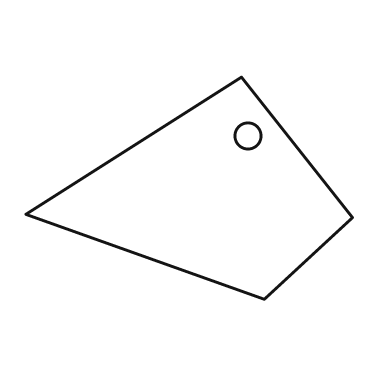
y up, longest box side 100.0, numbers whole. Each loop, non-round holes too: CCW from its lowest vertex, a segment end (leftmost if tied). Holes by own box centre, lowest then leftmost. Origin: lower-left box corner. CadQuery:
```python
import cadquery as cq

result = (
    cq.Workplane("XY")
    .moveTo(73.0, 0.0)
    .lineTo(100.0, 25.0)
    .lineTo(66.0, 68.0)
    .lineTo(0.0, 26.0)
    .close()
    .moveTo(68.0, 50.0)
    .circle(4.0)
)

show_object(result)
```